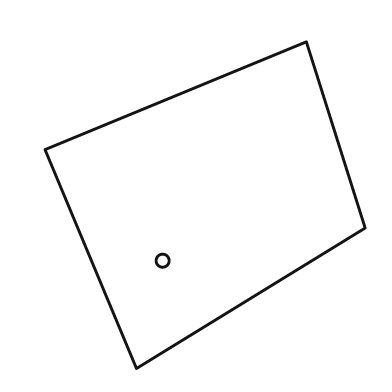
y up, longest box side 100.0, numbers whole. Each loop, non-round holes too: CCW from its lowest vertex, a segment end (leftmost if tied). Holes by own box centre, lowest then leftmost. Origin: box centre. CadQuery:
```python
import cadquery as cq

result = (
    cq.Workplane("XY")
    .moveTo(-21.0, -50.0)
    .lineTo(49.0, -7.0)
    .lineTo(31.0, 50.0)
    .lineTo(-49.0, 17.0)
    .close()
    .moveTo(-13.0, -17.0)
    .circle(2.0)
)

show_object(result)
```